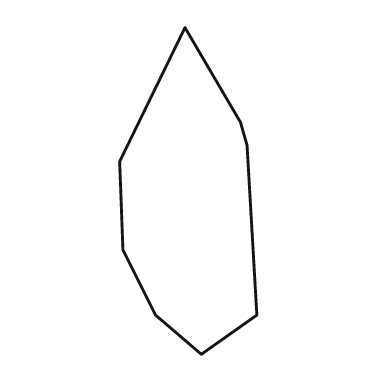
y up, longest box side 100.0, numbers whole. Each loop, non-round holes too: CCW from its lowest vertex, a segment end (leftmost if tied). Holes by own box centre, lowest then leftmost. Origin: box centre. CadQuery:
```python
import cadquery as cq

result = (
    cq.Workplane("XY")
    .moveTo(4.0, -50.0)
    .lineTo(21.0, -38.0)
    .lineTo(18.0, 14.0)
    .lineTo(16.0, 21.0)
    .lineTo(-1.0, 50.0)
    .lineTo(-21.0, 9.0)
    .lineTo(-20.0, -18.0)
    .lineTo(-10.0, -38.0)
    .close()
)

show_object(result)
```